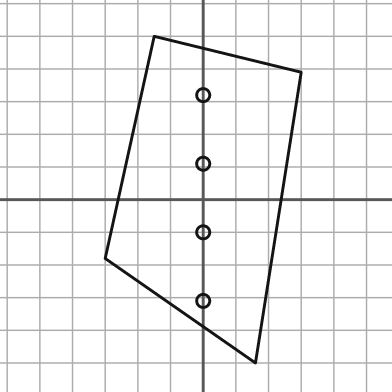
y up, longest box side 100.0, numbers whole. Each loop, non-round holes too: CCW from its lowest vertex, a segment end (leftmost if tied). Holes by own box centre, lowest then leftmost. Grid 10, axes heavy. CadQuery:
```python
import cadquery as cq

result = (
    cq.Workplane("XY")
    .moveTo(16.0, -50.0)
    .lineTo(30.0, 39.0)
    .lineTo(-15.0, 50.0)
    .lineTo(-30.0, -18.0)
    .close()
    .moveTo(0.0, -31.0)
    .circle(2.0)
    .moveTo(0.0, -10.0)
    .circle(2.0)
    .moveTo(0.0, 11.0)
    .circle(2.0)
    .moveTo(0.0, 32.0)
    .circle(2.0)
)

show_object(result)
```